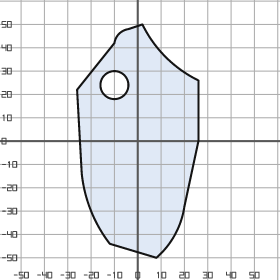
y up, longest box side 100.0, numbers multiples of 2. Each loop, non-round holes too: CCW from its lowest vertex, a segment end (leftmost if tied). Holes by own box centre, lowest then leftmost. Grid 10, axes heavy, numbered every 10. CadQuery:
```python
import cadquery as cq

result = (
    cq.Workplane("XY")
    .moveTo(8.0, -50.0)
    .threePointArc((16.0, -40.0), (20.0, -28.0))
    .lineTo(26.0, 0.0)
    .lineTo(26.0, 26.0)
    .threePointArc((12.0, 36.0), (2.0, 50.0))
    .lineTo(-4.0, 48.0)
    .threePointArc((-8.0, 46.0), (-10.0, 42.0))
    .lineTo(-26.0, 22.0)
    .lineTo(-24.0, -14.0)
    .threePointArc((-20.0, -30.0), (-12.0, -44.0))
    .close()
    .moveTo(-10.0, 24.0)
    .circle(6.0)
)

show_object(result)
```